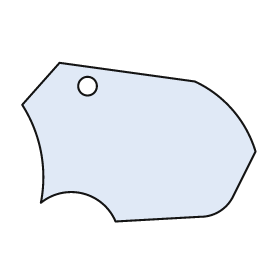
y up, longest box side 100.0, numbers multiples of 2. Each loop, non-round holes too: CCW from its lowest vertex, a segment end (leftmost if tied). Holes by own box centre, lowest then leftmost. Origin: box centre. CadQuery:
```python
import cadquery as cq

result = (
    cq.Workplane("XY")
    .moveTo(-10.0, -34.0)
    .lineTo(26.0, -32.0)
    .threePointArc((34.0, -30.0), (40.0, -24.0))
    .lineTo(50.0, -4.0)
    .threePointArc((40.0, 14.0), (24.0, 26.0))
    .lineTo(-34.0, 34.0)
    .lineTo(-50.0, 16.0)
    .threePointArc((-42.0, -4.0), (-42.0, -26.0))
    .threePointArc((-24.0, -22.0), (-10.0, -34.0))
    .close()
    .moveTo(-22.0, 24.0)
    .circle(4.0)
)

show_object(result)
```